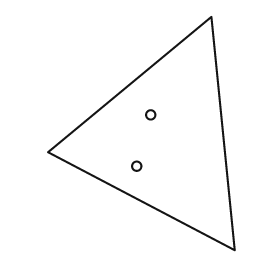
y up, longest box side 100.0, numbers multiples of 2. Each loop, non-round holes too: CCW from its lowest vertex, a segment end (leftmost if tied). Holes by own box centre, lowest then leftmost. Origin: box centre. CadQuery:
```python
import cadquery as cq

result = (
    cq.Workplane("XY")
    .moveTo(40.0, -50.0)
    .lineTo(30.0, 50.0)
    .lineTo(-40.0, -8.0)
    .close()
    .moveTo(-2.0, -14.0)
    .circle(2.0)
    .moveTo(4.0, 8.0)
    .circle(2.0)
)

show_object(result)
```